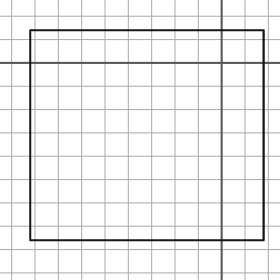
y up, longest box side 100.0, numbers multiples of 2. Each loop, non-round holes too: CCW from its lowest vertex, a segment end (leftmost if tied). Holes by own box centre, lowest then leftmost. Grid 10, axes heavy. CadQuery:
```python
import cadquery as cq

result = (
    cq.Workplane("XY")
    .moveTo(-82.0, -76.0)
    .lineTo(18.0, -76.0)
    .lineTo(18.0, 14.0)
    .lineTo(-82.0, 14.0)
    .close()
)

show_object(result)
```